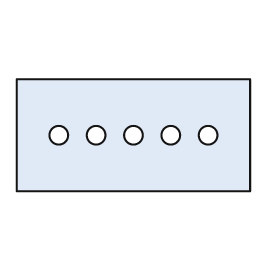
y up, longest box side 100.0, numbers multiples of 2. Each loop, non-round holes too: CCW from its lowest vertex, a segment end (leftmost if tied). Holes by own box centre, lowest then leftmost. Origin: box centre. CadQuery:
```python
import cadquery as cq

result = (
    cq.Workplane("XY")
    .moveTo(-50.0, -24.0)
    .lineTo(50.0, -24.0)
    .lineTo(50.0, 24.0)
    .lineTo(-50.0, 24.0)
    .close()
    .moveTo(-32.0, 0.0)
    .circle(4.0)
    .moveTo(-16.0, 0.0)
    .circle(4.0)
    .moveTo(0.0, 0.0)
    .circle(4.0)
    .moveTo(16.0, 0.0)
    .circle(4.0)
    .moveTo(32.0, 0.0)
    .circle(4.0)
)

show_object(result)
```